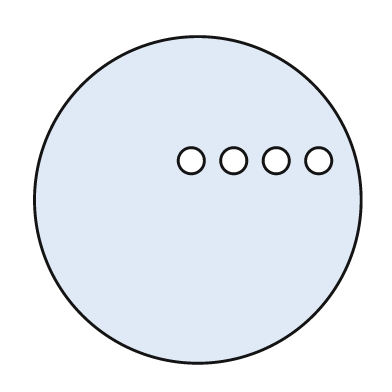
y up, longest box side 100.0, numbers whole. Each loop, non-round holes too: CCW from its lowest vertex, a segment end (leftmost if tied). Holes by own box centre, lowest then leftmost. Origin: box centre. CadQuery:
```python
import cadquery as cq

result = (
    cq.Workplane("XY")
    .moveTo(0.0, 0.0)
    .circle(50.0)
    .moveTo(-2.0, 12.0)
    .circle(4.0)
    .moveTo(11.0, 12.0)
    .circle(4.0)
    .moveTo(24.0, 12.0)
    .circle(4.0)
    .moveTo(37.0, 12.0)
    .circle(4.0)
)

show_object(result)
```